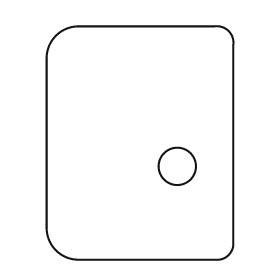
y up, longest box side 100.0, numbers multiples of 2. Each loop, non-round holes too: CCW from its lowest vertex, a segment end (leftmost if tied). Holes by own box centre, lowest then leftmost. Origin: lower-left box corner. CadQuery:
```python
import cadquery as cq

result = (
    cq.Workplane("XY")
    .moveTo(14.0, 0.0)
    .lineTo(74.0, 0.0)
    .threePointArc((78.0, 2.0), (80.0, 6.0))
    .lineTo(80.0, 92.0)
    .threePointArc((78.0, 98.0), (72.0, 100.0))
    .lineTo(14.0, 100.0)
    .threePointArc((4.0, 96.0), (0.0, 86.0))
    .lineTo(0.0, 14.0)
    .threePointArc((4.0, 4.0), (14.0, 0.0))
    .close()
    .moveTo(56.0, 40.0)
    .circle(8.0)
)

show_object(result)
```